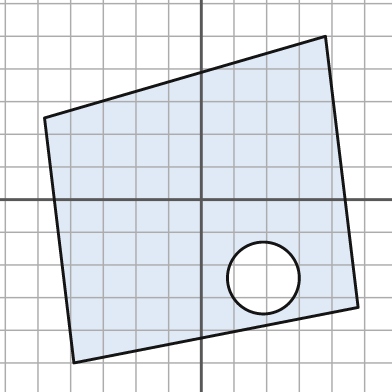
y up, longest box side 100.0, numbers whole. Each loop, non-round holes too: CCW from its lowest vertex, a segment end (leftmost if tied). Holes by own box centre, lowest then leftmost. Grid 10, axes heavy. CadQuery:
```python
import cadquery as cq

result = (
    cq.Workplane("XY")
    .moveTo(-39.0, -50.0)
    .lineTo(48.0, -33.0)
    .lineTo(38.0, 50.0)
    .lineTo(-48.0, 25.0)
    .close()
    .moveTo(19.0, -24.0)
    .circle(11.0)
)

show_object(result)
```